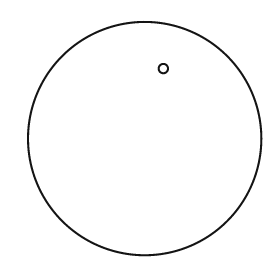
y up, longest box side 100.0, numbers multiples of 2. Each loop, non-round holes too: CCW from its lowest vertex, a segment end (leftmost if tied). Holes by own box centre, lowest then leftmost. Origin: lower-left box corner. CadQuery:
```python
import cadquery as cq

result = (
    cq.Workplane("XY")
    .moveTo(50.0, 50.0)
    .circle(50.0)
    .moveTo(58.0, 80.0)
    .circle(2.0)
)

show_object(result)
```